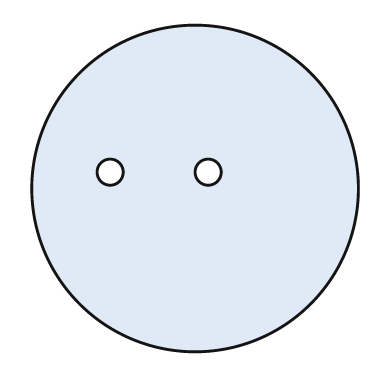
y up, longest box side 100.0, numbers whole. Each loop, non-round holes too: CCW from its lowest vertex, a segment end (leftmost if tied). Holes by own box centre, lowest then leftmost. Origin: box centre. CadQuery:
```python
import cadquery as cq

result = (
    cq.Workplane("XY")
    .moveTo(0.0, 0.0)
    .circle(50.0)
    .moveTo(-26.0, 5.0)
    .circle(4.0)
    .moveTo(4.0, 5.0)
    .circle(4.0)
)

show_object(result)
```